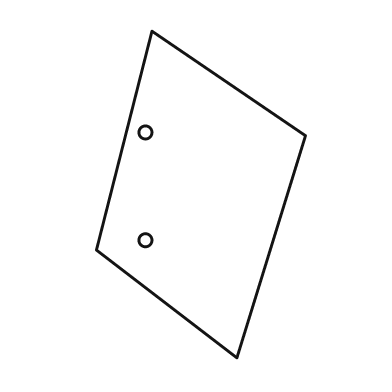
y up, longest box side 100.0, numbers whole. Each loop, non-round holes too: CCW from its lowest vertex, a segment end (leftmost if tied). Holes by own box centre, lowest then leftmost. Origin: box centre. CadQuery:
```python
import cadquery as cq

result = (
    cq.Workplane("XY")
    .moveTo(11.0, -50.0)
    .lineTo(32.0, 18.0)
    .lineTo(-15.0, 50.0)
    .lineTo(-32.0, -17.0)
    .close()
    .moveTo(-17.0, -14.0)
    .circle(2.0)
    .moveTo(-17.0, 19.0)
    .circle(2.0)
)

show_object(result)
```